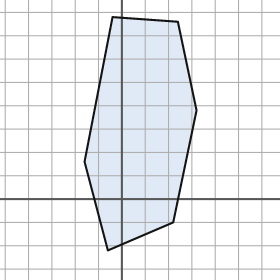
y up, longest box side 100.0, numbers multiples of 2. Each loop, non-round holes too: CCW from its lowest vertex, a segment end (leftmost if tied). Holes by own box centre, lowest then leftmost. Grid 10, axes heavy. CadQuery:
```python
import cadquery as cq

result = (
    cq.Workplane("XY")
    .moveTo(-6.0, -22.0)
    .lineTo(22.0, -10.0)
    .lineTo(32.0, 38.0)
    .lineTo(24.0, 76.0)
    .lineTo(-4.0, 78.0)
    .lineTo(-16.0, 16.0)
    .close()
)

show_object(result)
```